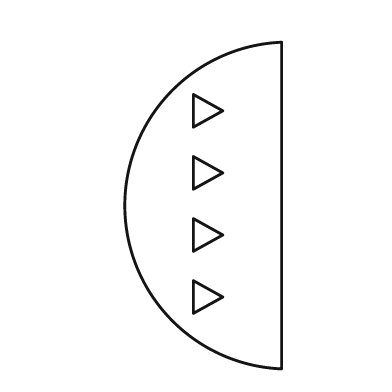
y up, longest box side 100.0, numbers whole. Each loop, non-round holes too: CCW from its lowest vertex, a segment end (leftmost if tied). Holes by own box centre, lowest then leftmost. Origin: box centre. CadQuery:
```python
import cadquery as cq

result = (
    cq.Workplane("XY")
    .moveTo(24.0, -50.0)
    .lineTo(24.0, 50.0)
    .threePointArc((-24.0, 0.0), (24.0, -50.0))
    .close()
    .moveTo(-3.0, -33.0)
    .lineTo(6.0, -28.0)
    .lineTo(-3.0, -23.0)
    .close()
    .moveTo(-3.0, -14.0)
    .lineTo(6.0, -9.0)
    .lineTo(-3.0, -4.0)
    .close()
    .moveTo(-3.0, 5.0)
    .lineTo(6.0, 10.0)
    .lineTo(-3.0, 15.0)
    .close()
    .moveTo(-3.0, 24.0)
    .lineTo(6.0, 29.0)
    .lineTo(-3.0, 34.0)
    .close()
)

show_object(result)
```